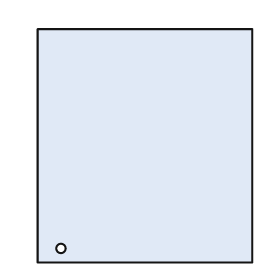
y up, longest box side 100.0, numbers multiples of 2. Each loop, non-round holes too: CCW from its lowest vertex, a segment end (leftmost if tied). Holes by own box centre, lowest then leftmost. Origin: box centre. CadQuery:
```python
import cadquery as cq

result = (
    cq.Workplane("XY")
    .moveTo(-46.0, -50.0)
    .lineTo(46.0, -50.0)
    .lineTo(46.0, 50.0)
    .lineTo(-46.0, 50.0)
    .close()
    .moveTo(-36.0, -44.0)
    .circle(2.0)
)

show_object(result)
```